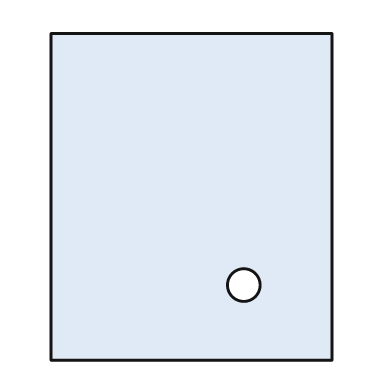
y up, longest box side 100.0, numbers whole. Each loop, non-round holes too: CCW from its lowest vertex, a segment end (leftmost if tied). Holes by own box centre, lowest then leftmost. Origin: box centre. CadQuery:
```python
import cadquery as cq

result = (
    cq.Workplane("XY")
    .moveTo(-43.0, -50.0)
    .lineTo(43.0, -50.0)
    .lineTo(43.0, 50.0)
    .lineTo(-43.0, 50.0)
    .close()
    .moveTo(16.0, -27.0)
    .circle(5.0)
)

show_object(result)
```